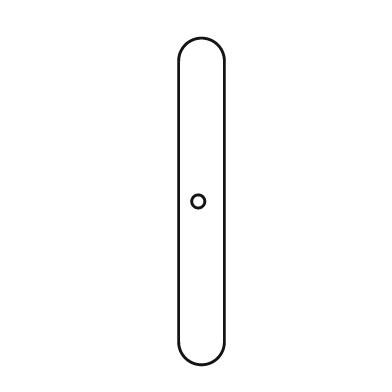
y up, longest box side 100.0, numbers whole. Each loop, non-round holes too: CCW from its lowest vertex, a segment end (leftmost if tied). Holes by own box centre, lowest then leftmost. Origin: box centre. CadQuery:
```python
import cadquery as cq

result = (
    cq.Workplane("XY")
    .moveTo(-7.0, -43.0)
    .threePointArc((0.0, -50.0), (7.0, -43.0))
    .lineTo(7.0, 43.0)
    .threePointArc((0.0, 50.0), (-7.0, 43.0))
    .close()
    .moveTo(-1.0, 0.0)
    .circle(2.0)
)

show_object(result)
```